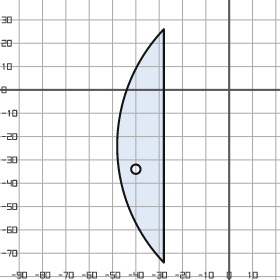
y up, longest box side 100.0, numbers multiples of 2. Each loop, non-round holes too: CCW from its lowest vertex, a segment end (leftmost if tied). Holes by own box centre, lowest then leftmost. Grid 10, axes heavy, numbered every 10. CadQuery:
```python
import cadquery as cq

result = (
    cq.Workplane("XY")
    .moveTo(-28.0, -74.0)
    .lineTo(-28.0, 26.0)
    .threePointArc((-48.0, -24.0), (-28.0, -74.0))
    .close()
    .moveTo(-40.0, -34.0)
    .circle(2.0)
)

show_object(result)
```